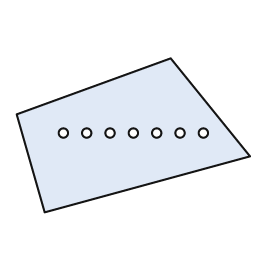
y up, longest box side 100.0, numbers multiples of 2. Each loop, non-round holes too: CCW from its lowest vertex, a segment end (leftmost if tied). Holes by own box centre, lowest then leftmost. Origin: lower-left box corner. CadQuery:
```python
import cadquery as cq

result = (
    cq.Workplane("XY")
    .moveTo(12.0, 0.0)
    .lineTo(100.0, 24.0)
    .lineTo(66.0, 66.0)
    .lineTo(0.0, 42.0)
    .close()
    .moveTo(20.0, 34.0)
    .circle(2.0)
    .moveTo(30.0, 34.0)
    .circle(2.0)
    .moveTo(40.0, 34.0)
    .circle(2.0)
    .moveTo(50.0, 34.0)
    .circle(2.0)
    .moveTo(60.0, 34.0)
    .circle(2.0)
    .moveTo(70.0, 34.0)
    .circle(2.0)
    .moveTo(80.0, 34.0)
    .circle(2.0)
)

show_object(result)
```